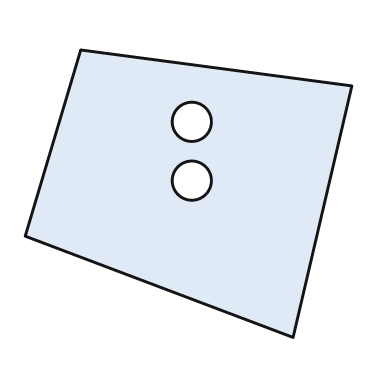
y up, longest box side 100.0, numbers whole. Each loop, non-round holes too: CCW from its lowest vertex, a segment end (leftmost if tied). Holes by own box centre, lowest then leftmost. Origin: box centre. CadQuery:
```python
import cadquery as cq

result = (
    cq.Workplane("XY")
    .moveTo(32.0, -44.0)
    .lineTo(50.0, 33.0)
    .lineTo(-33.0, 44.0)
    .lineTo(-50.0, -13.0)
    .close()
    .moveTo(1.0, 4.0)
    .circle(6.0)
    .moveTo(1.0, 22.0)
    .circle(6.0)
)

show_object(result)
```